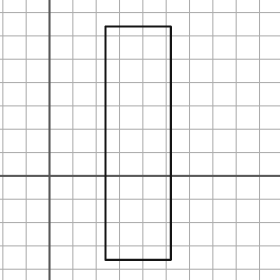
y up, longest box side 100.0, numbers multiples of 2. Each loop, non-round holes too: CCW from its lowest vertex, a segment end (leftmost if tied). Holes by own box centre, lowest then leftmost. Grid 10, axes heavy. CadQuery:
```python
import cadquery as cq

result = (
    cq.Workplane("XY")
    .moveTo(24.0, -36.0)
    .lineTo(52.0, -36.0)
    .lineTo(52.0, 64.0)
    .lineTo(24.0, 64.0)
    .close()
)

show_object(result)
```